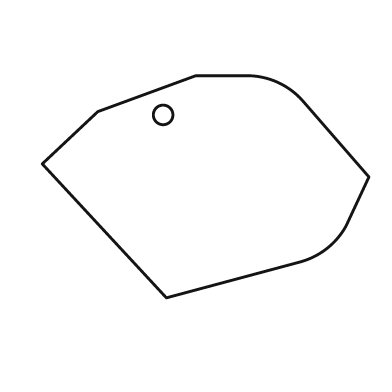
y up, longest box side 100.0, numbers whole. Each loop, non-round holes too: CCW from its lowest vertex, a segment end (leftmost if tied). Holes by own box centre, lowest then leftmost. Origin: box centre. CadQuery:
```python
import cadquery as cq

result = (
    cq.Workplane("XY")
    .moveTo(-12.0, -34.0)
    .lineTo(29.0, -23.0)
    .threePointArc((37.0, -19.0), (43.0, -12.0))
    .lineTo(50.0, 3.0)
    .lineTo(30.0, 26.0)
    .threePointArc((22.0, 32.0), (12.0, 34.0))
    .lineTo(-3.0, 34.0)
    .lineTo(-33.0, 23.0)
    .lineTo(-50.0, 7.0)
    .close()
    .moveTo(-13.0, 22.0)
    .circle(3.0)
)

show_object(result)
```